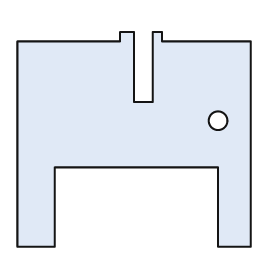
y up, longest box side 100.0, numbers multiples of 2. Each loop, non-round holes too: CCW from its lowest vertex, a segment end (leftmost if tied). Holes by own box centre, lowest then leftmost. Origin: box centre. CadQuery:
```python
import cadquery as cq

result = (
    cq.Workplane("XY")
    .moveTo(-50.0, -46.0)
    .lineTo(-34.0, -46.0)
    .lineTo(-34.0, -12.0)
    .lineTo(36.0, -12.0)
    .lineTo(36.0, -46.0)
    .lineTo(50.0, -46.0)
    .lineTo(50.0, 42.0)
    .lineTo(12.0, 42.0)
    .lineTo(12.0, 46.0)
    .lineTo(8.0, 46.0)
    .lineTo(8.0, 16.0)
    .lineTo(0.0, 16.0)
    .lineTo(0.0, 46.0)
    .lineTo(-6.0, 46.0)
    .lineTo(-6.0, 42.0)
    .lineTo(-50.0, 42.0)
    .close()
    .moveTo(36.0, 8.0)
    .circle(4.0)
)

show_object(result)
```